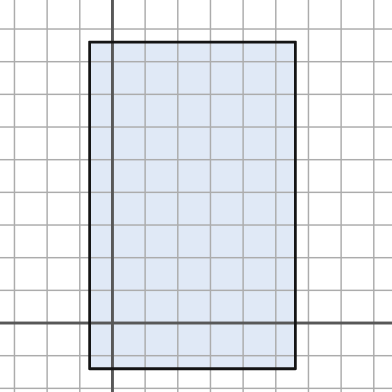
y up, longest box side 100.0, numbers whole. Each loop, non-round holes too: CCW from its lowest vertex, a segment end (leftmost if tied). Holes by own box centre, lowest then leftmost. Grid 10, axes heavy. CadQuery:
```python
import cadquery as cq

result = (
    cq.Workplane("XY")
    .moveTo(-7.0, -14.0)
    .lineTo(56.0, -14.0)
    .lineTo(56.0, 86.0)
    .lineTo(-7.0, 86.0)
    .close()
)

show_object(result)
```